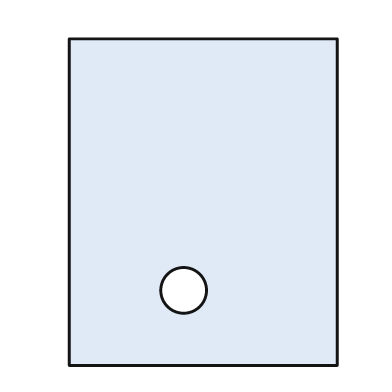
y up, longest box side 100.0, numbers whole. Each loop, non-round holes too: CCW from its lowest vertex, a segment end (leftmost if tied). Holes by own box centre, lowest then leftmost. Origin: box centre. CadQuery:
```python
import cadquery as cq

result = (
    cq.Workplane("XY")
    .moveTo(-41.0, -50.0)
    .lineTo(41.0, -50.0)
    .lineTo(41.0, 50.0)
    .lineTo(-41.0, 50.0)
    .close()
    .moveTo(-6.0, -27.0)
    .circle(7.0)
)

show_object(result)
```